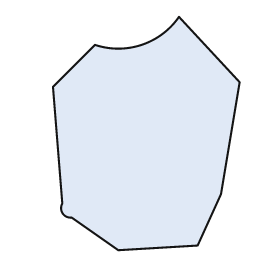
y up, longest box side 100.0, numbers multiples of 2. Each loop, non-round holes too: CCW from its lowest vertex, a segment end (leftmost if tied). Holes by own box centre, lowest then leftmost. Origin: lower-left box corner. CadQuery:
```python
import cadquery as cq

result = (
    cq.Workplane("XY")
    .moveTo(28.0, 0.0)
    .lineTo(62.0, 2.0)
    .lineTo(72.0, 24.0)
    .lineTo(80.0, 72.0)
    .lineTo(54.0, 100.0)
    .threePointArc((38.0, 88.0), (18.0, 88.0))
    .lineTo(0.0, 70.0)
    .lineTo(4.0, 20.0)
    .threePointArc((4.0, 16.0), (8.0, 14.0))
    .close()
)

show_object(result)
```